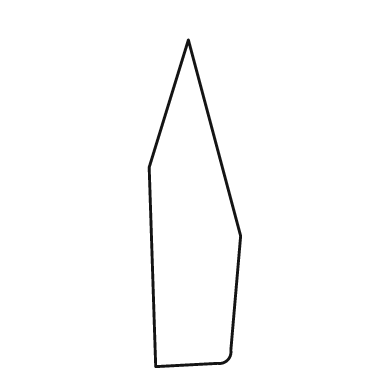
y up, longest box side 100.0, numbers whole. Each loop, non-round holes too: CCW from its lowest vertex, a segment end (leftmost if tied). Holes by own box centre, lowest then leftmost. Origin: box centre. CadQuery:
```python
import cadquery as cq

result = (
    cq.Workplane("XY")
    .moveTo(-12.0, -50.0)
    .lineTo(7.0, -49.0)
    .threePointArc((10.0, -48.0), (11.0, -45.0))
    .lineTo(14.0, -10.0)
    .lineTo(-2.0, 50.0)
    .lineTo(-14.0, 11.0)
    .close()
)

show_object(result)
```